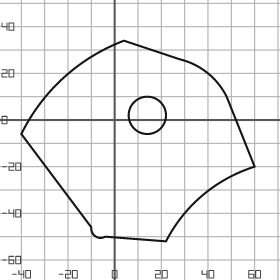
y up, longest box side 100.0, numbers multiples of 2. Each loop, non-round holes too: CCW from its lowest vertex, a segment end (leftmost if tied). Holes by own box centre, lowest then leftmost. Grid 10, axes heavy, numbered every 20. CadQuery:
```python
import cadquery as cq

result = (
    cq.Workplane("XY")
    .moveTo(22.0, -52.0)
    .threePointArc((38.0, -32.0), (60.0, -20.0))
    .lineTo(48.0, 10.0)
    .threePointArc((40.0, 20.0), (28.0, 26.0))
    .lineTo(4.0, 34.0)
    .threePointArc((-22.0, 18.0), (-40.0, -6.0))
    .lineTo(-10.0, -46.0)
    .threePointArc((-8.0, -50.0), (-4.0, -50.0))
    .close()
    .moveTo(14.0, 2.0)
    .circle(8.0)
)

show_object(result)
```